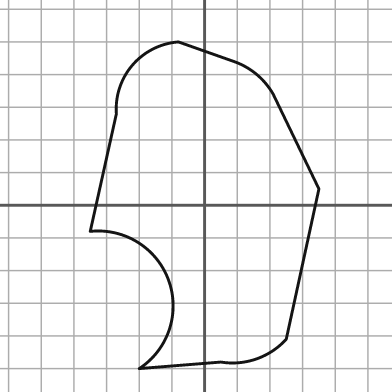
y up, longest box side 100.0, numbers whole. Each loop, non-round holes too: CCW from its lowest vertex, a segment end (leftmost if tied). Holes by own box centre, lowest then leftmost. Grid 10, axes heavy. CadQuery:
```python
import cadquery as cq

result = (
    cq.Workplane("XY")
    .moveTo(-20.0, -50.0)
    .lineTo(5.0, -48.0)
    .threePointArc((16.0, -47.0), (25.0, -41.0))
    .lineTo(35.0, 5.0)
    .lineTo(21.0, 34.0)
    .threePointArc((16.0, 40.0), (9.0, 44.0))
    .lineTo(-8.0, 50.0)
    .threePointArc((-22.0, 43.0), (-27.0, 28.0))
    .lineTo(-35.0, -8.0)
    .threePointArc((-11.0, -23.0), (-20.0, -50.0))
    .close()
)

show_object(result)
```